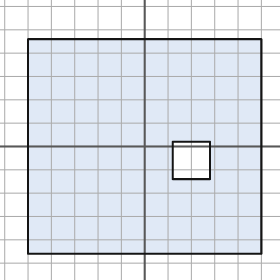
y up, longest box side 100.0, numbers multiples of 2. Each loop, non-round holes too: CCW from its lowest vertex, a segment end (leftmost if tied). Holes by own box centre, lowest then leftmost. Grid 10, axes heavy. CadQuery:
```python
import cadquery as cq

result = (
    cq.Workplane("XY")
    .moveTo(-50.0, -46.0)
    .lineTo(50.0, -46.0)
    .lineTo(50.0, 46.0)
    .lineTo(-50.0, 46.0)
    .close()
    .moveTo(12.0, -14.0)
    .lineTo(28.0, -14.0)
    .lineTo(28.0, 2.0)
    .lineTo(12.0, 2.0)
    .close()
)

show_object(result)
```